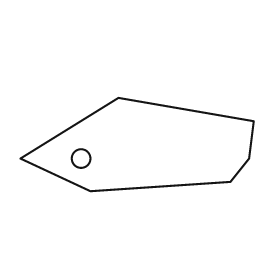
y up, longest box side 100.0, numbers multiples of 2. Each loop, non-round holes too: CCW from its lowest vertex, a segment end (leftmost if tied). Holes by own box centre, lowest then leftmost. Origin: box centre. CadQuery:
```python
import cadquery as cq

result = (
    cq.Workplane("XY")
    .moveTo(-20.0, -20.0)
    .lineTo(40.0, -16.0)
    .lineTo(48.0, -6.0)
    .lineTo(50.0, 10.0)
    .lineTo(-8.0, 20.0)
    .lineTo(-50.0, -6.0)
    .close()
    .moveTo(-24.0, -6.0)
    .circle(4.0)
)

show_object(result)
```